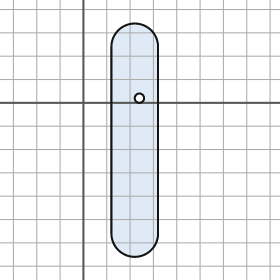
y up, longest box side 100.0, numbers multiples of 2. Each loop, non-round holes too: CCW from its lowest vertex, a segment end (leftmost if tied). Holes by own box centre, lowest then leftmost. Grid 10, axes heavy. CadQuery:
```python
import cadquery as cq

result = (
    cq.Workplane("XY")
    .moveTo(12.0, -56.0)
    .threePointArc((22.0, -66.0), (32.0, -56.0))
    .lineTo(32.0, 24.0)
    .threePointArc((22.0, 34.0), (12.0, 24.0))
    .close()
    .moveTo(24.0, 2.0)
    .circle(2.0)
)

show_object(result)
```